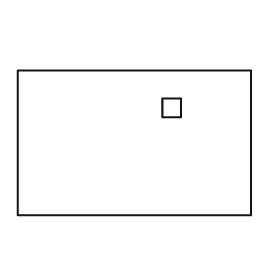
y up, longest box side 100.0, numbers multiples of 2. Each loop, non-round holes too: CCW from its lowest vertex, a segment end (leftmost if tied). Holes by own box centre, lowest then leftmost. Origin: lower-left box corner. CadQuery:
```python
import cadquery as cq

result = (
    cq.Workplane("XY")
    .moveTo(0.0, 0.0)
    .lineTo(100.0, 0.0)
    .lineTo(100.0, 62.0)
    .lineTo(0.0, 62.0)
    .close()
    .moveTo(62.0, 42.0)
    .lineTo(70.0, 42.0)
    .lineTo(70.0, 50.0)
    .lineTo(62.0, 50.0)
    .close()
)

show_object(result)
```